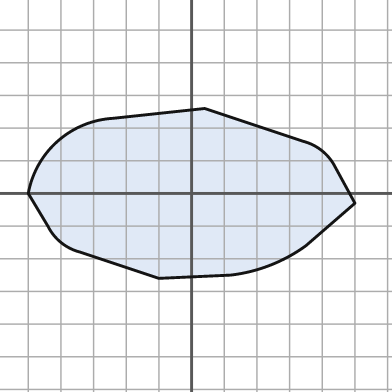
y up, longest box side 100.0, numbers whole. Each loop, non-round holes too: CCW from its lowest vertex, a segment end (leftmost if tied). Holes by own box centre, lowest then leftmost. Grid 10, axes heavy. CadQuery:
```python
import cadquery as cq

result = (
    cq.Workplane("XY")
    .moveTo(-10.0, -26.0)
    .lineTo(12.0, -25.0)
    .threePointArc((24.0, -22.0), (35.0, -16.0))
    .lineTo(50.0, -3.0)
    .lineTo(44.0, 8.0)
    .threePointArc((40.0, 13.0), (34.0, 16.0))
    .lineTo(4.0, 26.0)
    .lineTo(-24.0, 23.0)
    .threePointArc((-41.0, 16.0), (-50.0, 0.0))
    .lineTo(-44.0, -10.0)
    .threePointArc((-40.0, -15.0), (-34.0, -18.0))
    .close()
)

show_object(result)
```